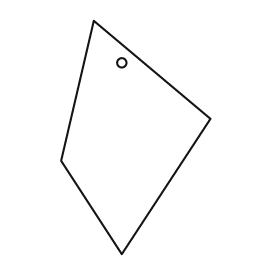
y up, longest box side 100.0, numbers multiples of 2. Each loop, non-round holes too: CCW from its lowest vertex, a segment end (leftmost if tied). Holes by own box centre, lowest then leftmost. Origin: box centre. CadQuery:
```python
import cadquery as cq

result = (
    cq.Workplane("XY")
    .moveTo(-6.0, -50.0)
    .lineTo(32.0, 8.0)
    .lineTo(-18.0, 50.0)
    .lineTo(-32.0, -10.0)
    .close()
    .moveTo(-6.0, 32.0)
    .circle(2.0)
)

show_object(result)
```